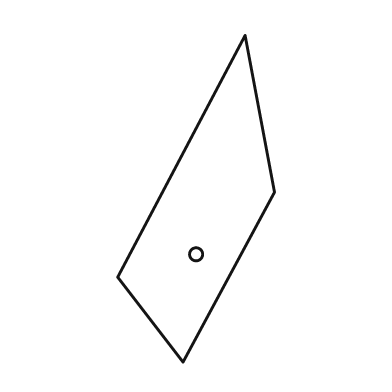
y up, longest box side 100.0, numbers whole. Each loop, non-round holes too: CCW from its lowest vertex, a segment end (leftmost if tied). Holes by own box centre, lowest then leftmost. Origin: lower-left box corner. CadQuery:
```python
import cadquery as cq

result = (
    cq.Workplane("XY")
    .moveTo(20.0, 0.0)
    .lineTo(48.0, 52.0)
    .lineTo(39.0, 100.0)
    .lineTo(0.0, 26.0)
    .close()
    .moveTo(24.0, 33.0)
    .circle(2.0)
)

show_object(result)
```